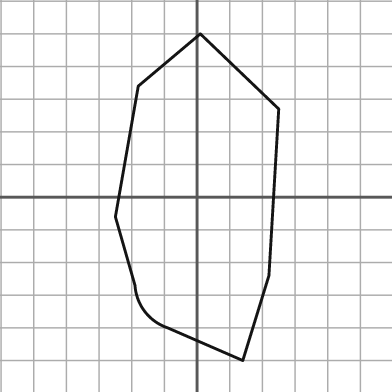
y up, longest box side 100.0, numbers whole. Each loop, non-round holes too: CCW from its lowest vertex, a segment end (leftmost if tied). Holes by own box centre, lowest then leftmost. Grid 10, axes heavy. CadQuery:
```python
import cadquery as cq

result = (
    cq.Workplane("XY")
    .moveTo(14.0, -50.0)
    .lineTo(22.0, -24.0)
    .lineTo(25.0, 27.0)
    .lineTo(1.0, 50.0)
    .lineTo(-18.0, 34.0)
    .lineTo(-25.0, -6.0)
    .lineTo(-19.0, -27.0)
    .threePointArc((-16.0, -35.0), (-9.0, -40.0))
    .close()
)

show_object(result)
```